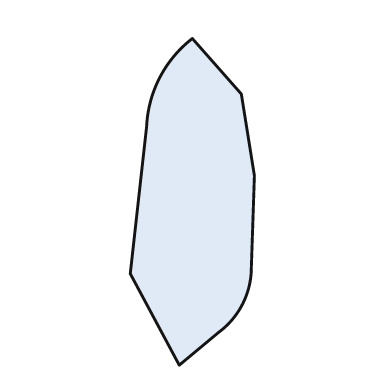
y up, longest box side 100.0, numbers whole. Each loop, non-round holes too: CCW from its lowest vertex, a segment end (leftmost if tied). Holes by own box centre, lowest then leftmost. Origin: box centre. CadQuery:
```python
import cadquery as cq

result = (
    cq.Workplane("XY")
    .moveTo(-4.0, -50.0)
    .lineTo(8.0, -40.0)
    .threePointArc((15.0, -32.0), (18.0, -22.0))
    .lineTo(19.0, 8.0)
    .lineTo(15.0, 33.0)
    .lineTo(0.0, 50.0)
    .threePointArc((-10.0, 38.0), (-14.0, 23.0))
    .lineTo(-19.0, -22.0)
    .close()
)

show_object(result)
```